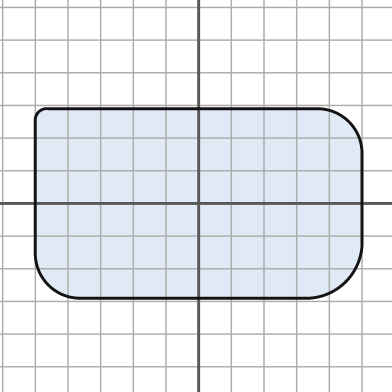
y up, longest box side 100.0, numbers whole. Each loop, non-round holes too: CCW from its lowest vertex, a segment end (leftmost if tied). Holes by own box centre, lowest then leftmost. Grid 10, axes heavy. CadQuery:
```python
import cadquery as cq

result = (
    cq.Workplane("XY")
    .moveTo(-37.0, -29.0)
    .lineTo(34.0, -29.0)
    .threePointArc((45.0, -24.0), (50.0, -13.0))
    .lineTo(50.0, 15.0)
    .threePointArc((46.0, 25.0), (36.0, 29.0))
    .lineTo(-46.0, 29.0)
    .threePointArc((-49.0, 28.0), (-50.0, 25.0))
    .lineTo(-50.0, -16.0)
    .threePointArc((-46.0, -25.0), (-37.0, -29.0))
    .close()
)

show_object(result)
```